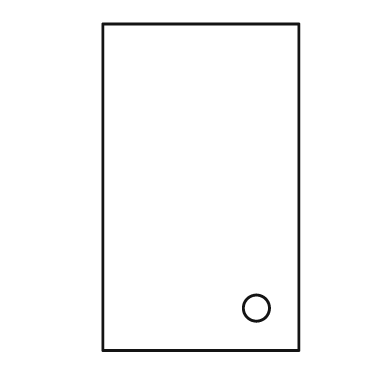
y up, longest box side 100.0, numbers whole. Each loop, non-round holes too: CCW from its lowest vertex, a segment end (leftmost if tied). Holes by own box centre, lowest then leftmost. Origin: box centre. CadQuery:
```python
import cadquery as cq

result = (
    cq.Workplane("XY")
    .moveTo(-30.0, -50.0)
    .lineTo(30.0, -50.0)
    .lineTo(30.0, 50.0)
    .lineTo(-30.0, 50.0)
    .close()
    .moveTo(17.0, -37.0)
    .circle(4.0)
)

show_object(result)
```